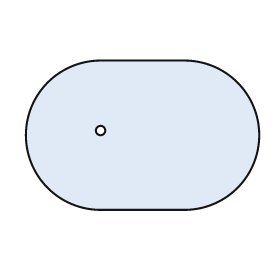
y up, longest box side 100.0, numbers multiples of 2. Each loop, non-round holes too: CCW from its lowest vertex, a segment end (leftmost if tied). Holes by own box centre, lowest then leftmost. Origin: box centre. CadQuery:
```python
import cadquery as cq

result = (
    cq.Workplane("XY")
    .moveTo(-18.0, -32.0)
    .lineTo(18.0, -32.0)
    .threePointArc((50.0, 0.0), (18.0, 32.0))
    .lineTo(-18.0, 32.0)
    .threePointArc((-50.0, 0.0), (-18.0, -32.0))
    .close()
    .moveTo(-18.0, 2.0)
    .circle(2.0)
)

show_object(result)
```